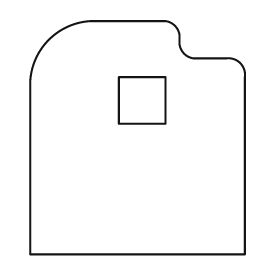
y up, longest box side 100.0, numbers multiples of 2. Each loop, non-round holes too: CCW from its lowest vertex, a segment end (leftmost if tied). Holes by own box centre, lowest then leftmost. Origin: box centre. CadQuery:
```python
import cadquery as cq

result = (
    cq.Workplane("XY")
    .moveTo(-46.0, -50.0)
    .lineTo(46.0, -50.0)
    .lineTo(46.0, 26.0)
    .threePointArc((44.0, 32.0), (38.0, 34.0))
    .lineTo(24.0, 34.0)
    .threePointArc((20.0, 36.0), (18.0, 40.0))
    .lineTo(18.0, 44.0)
    .threePointArc((16.0, 48.0), (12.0, 50.0))
    .lineTo(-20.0, 50.0)
    .threePointArc((-38.0, 42.0), (-46.0, 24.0))
    .close()
    .moveTo(-8.0, 6.0)
    .lineTo(12.0, 6.0)
    .lineTo(12.0, 26.0)
    .lineTo(-8.0, 26.0)
    .close()
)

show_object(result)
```